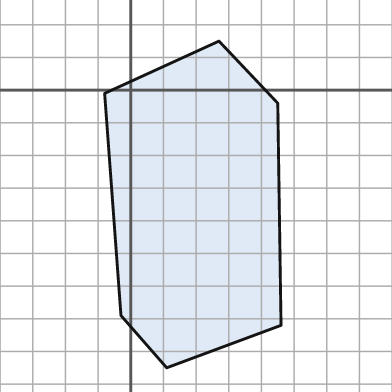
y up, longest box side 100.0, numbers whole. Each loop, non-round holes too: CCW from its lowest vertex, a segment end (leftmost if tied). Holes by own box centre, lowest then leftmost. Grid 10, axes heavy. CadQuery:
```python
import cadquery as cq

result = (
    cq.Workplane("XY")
    .moveTo(11.0, -85.0)
    .lineTo(46.0, -72.0)
    .lineTo(45.0, -4.0)
    .lineTo(27.0, 15.0)
    .lineTo(-8.0, -1.0)
    .lineTo(-3.0, -69.0)
    .close()
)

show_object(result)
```